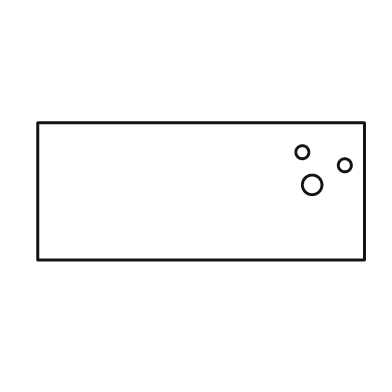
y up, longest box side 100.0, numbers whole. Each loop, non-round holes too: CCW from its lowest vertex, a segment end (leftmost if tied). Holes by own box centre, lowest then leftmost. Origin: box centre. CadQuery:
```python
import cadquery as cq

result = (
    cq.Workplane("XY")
    .moveTo(-50.0, -21.0)
    .lineTo(50.0, -21.0)
    .lineTo(50.0, 21.0)
    .lineTo(-50.0, 21.0)
    .close()
    .moveTo(34.0, 2.0)
    .circle(3.0)
    .moveTo(44.0, 8.0)
    .circle(2.0)
    .moveTo(31.0, 12.0)
    .circle(2.0)
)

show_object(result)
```